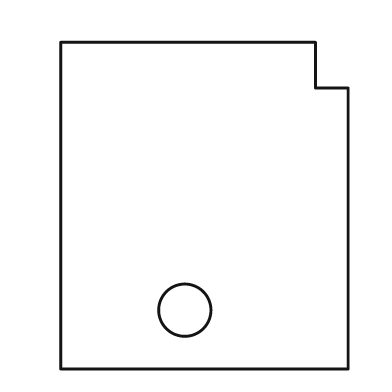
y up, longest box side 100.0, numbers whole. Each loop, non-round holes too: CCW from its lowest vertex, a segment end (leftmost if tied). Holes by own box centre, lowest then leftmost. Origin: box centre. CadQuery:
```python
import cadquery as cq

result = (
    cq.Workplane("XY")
    .moveTo(-44.0, -50.0)
    .lineTo(44.0, -50.0)
    .lineTo(44.0, 36.0)
    .lineTo(34.0, 36.0)
    .lineTo(34.0, 50.0)
    .lineTo(-44.0, 50.0)
    .close()
    .moveTo(-6.0, -32.0)
    .circle(8.0)
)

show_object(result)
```